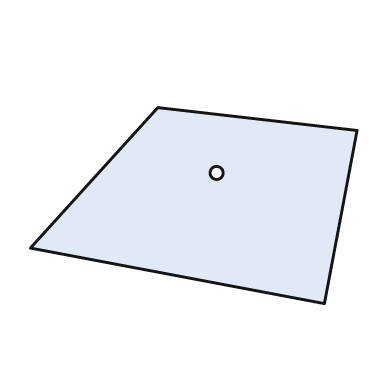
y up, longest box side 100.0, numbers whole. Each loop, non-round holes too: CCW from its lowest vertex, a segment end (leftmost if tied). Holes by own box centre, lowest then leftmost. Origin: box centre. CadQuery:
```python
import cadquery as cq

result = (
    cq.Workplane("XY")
    .moveTo(40.0, -30.0)
    .lineTo(50.0, 23.0)
    .lineTo(-11.0, 30.0)
    .lineTo(-50.0, -13.0)
    .close()
    .moveTo(7.0, 10.0)
    .circle(2.0)
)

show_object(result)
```